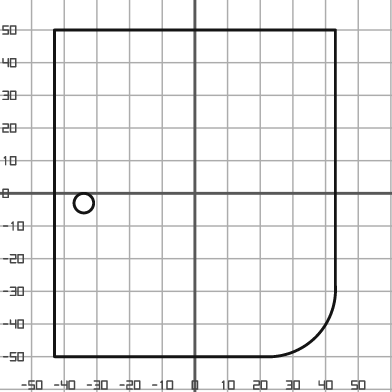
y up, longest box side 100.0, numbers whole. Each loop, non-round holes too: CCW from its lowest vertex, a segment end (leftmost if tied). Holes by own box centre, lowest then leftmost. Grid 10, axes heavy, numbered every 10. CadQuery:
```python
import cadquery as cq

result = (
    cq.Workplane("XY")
    .moveTo(-43.0, -50.0)
    .lineTo(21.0, -50.0)
    .threePointArc((37.0, -44.0), (43.0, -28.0))
    .lineTo(43.0, 50.0)
    .lineTo(-43.0, 50.0)
    .close()
    .moveTo(-34.0, -3.0)
    .circle(3.0)
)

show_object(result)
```